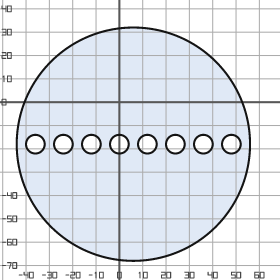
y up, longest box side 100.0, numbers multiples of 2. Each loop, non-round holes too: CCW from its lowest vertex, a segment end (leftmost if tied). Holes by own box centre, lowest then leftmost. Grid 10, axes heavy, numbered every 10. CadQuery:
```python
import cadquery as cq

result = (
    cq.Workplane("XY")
    .moveTo(6.0, -18.0)
    .circle(50.0)
    .moveTo(-36.0, -18.0)
    .circle(4.0)
    .moveTo(-24.0, -18.0)
    .circle(4.0)
    .moveTo(-12.0, -18.0)
    .circle(4.0)
    .moveTo(0.0, -18.0)
    .circle(4.0)
    .moveTo(12.0, -18.0)
    .circle(4.0)
    .moveTo(24.0, -18.0)
    .circle(4.0)
    .moveTo(36.0, -18.0)
    .circle(4.0)
    .moveTo(48.0, -18.0)
    .circle(4.0)
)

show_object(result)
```